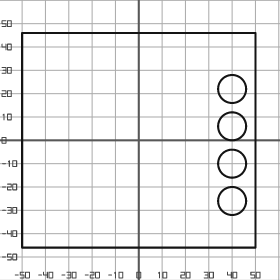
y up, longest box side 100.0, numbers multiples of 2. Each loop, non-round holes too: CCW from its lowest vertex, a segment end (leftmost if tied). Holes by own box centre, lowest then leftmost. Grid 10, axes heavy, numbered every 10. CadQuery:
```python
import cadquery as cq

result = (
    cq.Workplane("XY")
    .moveTo(-50.0, -46.0)
    .lineTo(50.0, -46.0)
    .lineTo(50.0, 46.0)
    .lineTo(-50.0, 46.0)
    .close()
    .moveTo(40.0, -26.0)
    .circle(6.0)
    .moveTo(40.0, -10.0)
    .circle(6.0)
    .moveTo(40.0, 6.0)
    .circle(6.0)
    .moveTo(40.0, 22.0)
    .circle(6.0)
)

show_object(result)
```